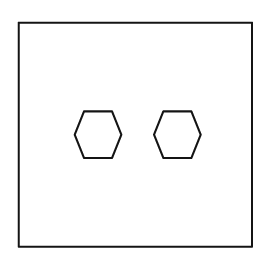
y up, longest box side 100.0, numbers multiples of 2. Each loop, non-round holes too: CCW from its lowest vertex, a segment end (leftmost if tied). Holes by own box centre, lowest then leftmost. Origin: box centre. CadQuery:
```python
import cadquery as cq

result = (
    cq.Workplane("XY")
    .moveTo(-50.0, -48.0)
    .lineTo(50.0, -48.0)
    .lineTo(50.0, 48.0)
    .lineTo(-50.0, 48.0)
    .close()
    .moveTo(-22.0, -10.0)
    .lineTo(-10.0, -10.0)
    .lineTo(-6.0, 0.0)
    .lineTo(-10.0, 10.0)
    .lineTo(-22.0, 10.0)
    .lineTo(-26.0, 0.0)
    .close()
    .moveTo(12.0, -10.0)
    .lineTo(24.0, -10.0)
    .lineTo(28.0, 0.0)
    .lineTo(24.0, 10.0)
    .lineTo(12.0, 10.0)
    .lineTo(8.0, 0.0)
    .close()
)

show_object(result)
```